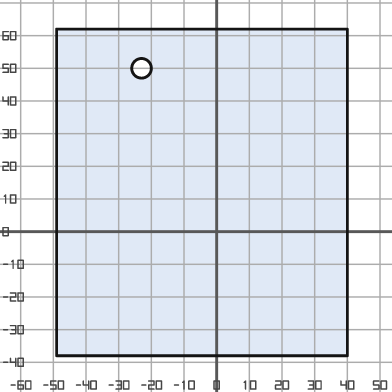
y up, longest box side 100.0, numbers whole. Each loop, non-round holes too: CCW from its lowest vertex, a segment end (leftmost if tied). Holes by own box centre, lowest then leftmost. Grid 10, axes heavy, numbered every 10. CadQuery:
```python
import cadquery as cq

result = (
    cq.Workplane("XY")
    .moveTo(-49.0, -38.0)
    .lineTo(40.0, -38.0)
    .lineTo(40.0, 62.0)
    .lineTo(-49.0, 62.0)
    .close()
    .moveTo(-23.0, 50.0)
    .circle(3.0)
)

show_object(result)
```